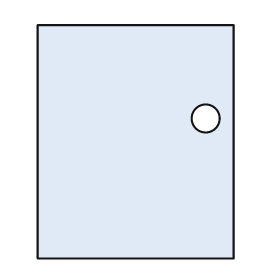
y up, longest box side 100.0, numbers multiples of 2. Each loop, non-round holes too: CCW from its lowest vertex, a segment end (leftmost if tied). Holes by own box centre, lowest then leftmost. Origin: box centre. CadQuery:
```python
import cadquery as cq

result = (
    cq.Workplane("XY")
    .moveTo(-42.0, -50.0)
    .lineTo(42.0, -50.0)
    .lineTo(42.0, 50.0)
    .lineTo(-42.0, 50.0)
    .close()
    .moveTo(30.0, 10.0)
    .circle(6.0)
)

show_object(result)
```